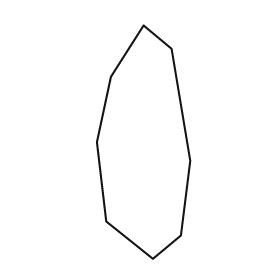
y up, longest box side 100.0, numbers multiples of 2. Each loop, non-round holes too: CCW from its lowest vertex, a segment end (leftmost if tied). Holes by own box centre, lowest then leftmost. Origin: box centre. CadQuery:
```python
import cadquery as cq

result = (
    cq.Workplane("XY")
    .moveTo(4.0, -50.0)
    .lineTo(16.0, -40.0)
    .lineTo(20.0, -8.0)
    .lineTo(12.0, 40.0)
    .lineTo(0.0, 50.0)
    .lineTo(-14.0, 28.0)
    .lineTo(-20.0, 0.0)
    .lineTo(-16.0, -34.0)
    .close()
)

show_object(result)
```